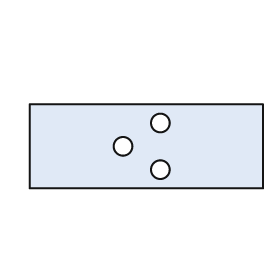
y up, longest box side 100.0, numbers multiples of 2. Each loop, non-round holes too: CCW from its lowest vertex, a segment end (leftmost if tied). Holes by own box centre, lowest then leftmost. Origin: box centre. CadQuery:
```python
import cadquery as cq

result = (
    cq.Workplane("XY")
    .moveTo(-50.0, -18.0)
    .lineTo(50.0, -18.0)
    .lineTo(50.0, 18.0)
    .lineTo(-50.0, 18.0)
    .close()
    .moveTo(6.0, -10.0)
    .circle(4.0)
    .moveTo(-10.0, 0.0)
    .circle(4.0)
    .moveTo(6.0, 10.0)
    .circle(4.0)
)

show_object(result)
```